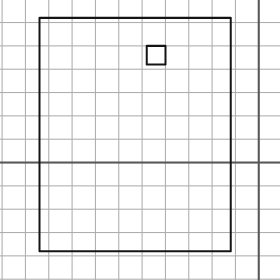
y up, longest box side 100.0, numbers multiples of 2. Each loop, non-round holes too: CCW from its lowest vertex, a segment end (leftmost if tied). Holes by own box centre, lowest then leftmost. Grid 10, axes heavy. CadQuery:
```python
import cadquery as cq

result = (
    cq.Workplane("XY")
    .moveTo(-94.0, -38.0)
    .lineTo(-12.0, -38.0)
    .lineTo(-12.0, 62.0)
    .lineTo(-94.0, 62.0)
    .close()
    .moveTo(-48.0, 42.0)
    .lineTo(-40.0, 42.0)
    .lineTo(-40.0, 50.0)
    .lineTo(-48.0, 50.0)
    .close()
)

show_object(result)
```